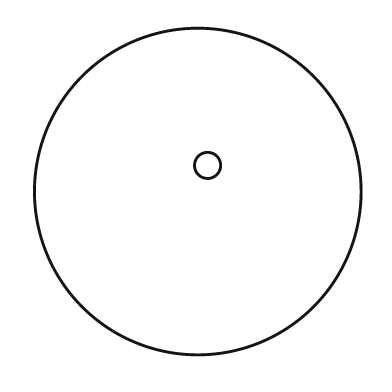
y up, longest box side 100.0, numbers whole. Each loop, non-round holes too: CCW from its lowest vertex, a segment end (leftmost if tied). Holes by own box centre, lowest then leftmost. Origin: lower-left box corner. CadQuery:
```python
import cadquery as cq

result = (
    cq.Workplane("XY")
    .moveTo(50.0, 50.0)
    .circle(50.0)
    .moveTo(53.0, 58.0)
    .circle(4.0)
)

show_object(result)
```